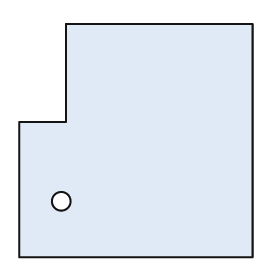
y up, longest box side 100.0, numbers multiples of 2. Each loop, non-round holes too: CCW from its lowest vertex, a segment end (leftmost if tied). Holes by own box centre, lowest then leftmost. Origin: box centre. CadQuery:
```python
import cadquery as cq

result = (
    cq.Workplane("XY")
    .moveTo(-50.0, -50.0)
    .lineTo(50.0, -50.0)
    .lineTo(50.0, 50.0)
    .lineTo(-30.0, 50.0)
    .lineTo(-30.0, 8.0)
    .lineTo(-50.0, 8.0)
    .close()
    .moveTo(-32.0, -26.0)
    .circle(4.0)
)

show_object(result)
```